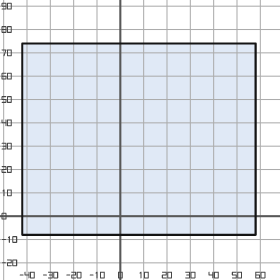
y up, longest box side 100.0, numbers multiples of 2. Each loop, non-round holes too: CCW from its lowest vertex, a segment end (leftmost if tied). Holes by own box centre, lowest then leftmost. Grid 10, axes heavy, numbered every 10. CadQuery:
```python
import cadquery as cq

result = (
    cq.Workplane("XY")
    .moveTo(-42.0, -8.0)
    .lineTo(58.0, -8.0)
    .lineTo(58.0, 74.0)
    .lineTo(-42.0, 74.0)
    .close()
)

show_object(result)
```